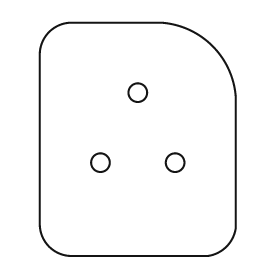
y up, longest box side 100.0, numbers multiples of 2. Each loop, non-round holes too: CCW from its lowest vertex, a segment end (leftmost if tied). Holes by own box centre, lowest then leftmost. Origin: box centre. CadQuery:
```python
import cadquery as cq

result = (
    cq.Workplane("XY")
    .moveTo(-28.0, -50.0)
    .lineTo(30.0, -50.0)
    .threePointArc((38.0, -46.0), (42.0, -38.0))
    .lineTo(42.0, 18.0)
    .threePointArc((32.0, 40.0), (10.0, 50.0))
    .lineTo(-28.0, 50.0)
    .threePointArc((-38.0, 46.0), (-42.0, 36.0))
    .lineTo(-42.0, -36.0)
    .threePointArc((-38.0, -46.0), (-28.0, -50.0))
    .close()
    .moveTo(-16.0, -10.0)
    .circle(4.0)
    .moveTo(16.0, -10.0)
    .circle(4.0)
    .moveTo(0.0, 20.0)
    .circle(4.0)
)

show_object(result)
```